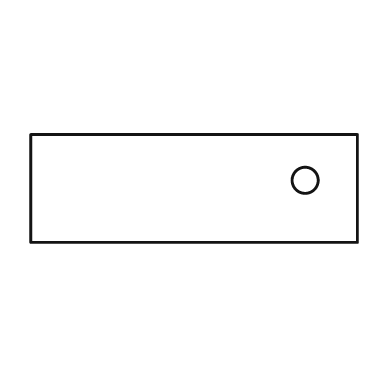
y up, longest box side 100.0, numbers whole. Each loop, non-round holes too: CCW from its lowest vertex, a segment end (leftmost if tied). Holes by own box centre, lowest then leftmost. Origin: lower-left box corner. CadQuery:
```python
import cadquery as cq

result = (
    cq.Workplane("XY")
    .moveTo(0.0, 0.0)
    .lineTo(100.0, 0.0)
    .lineTo(100.0, 33.0)
    .lineTo(0.0, 33.0)
    .close()
    .moveTo(84.0, 19.0)
    .circle(4.0)
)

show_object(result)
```